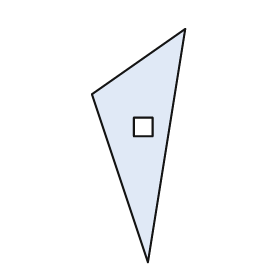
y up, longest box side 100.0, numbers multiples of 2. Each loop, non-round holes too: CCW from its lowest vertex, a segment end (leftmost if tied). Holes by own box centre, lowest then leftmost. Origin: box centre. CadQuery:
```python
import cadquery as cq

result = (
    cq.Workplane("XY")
    .moveTo(4.0, -50.0)
    .lineTo(20.0, 50.0)
    .lineTo(-20.0, 22.0)
    .close()
    .moveTo(-2.0, 4.0)
    .lineTo(6.0, 4.0)
    .lineTo(6.0, 12.0)
    .lineTo(-2.0, 12.0)
    .close()
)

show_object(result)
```